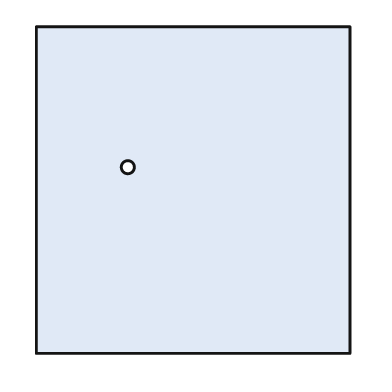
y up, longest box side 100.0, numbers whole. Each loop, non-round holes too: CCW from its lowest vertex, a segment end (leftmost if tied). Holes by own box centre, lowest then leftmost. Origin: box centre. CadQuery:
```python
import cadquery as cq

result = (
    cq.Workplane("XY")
    .moveTo(-48.0, -50.0)
    .lineTo(48.0, -50.0)
    .lineTo(48.0, 50.0)
    .lineTo(-48.0, 50.0)
    .close()
    .moveTo(-20.0, 7.0)
    .circle(2.0)
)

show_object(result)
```